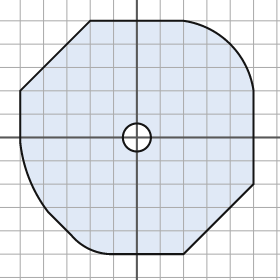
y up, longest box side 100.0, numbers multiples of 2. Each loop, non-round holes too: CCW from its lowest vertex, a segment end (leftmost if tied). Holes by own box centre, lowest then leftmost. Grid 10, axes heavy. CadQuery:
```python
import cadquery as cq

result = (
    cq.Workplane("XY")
    .moveTo(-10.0, -50.0)
    .lineTo(20.0, -50.0)
    .lineTo(50.0, -20.0)
    .lineTo(50.0, 20.0)
    .threePointArc((40.0, 40.0), (20.0, 50.0))
    .lineTo(-20.0, 50.0)
    .lineTo(-50.0, 20.0)
    .lineTo(-50.0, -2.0)
    .threePointArc((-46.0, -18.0), (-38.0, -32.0))
    .lineTo(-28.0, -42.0)
    .threePointArc((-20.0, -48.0), (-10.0, -50.0))
    .close()
    .moveTo(0.0, 0.0)
    .circle(6.0)
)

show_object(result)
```